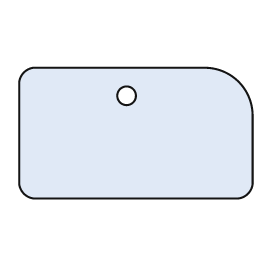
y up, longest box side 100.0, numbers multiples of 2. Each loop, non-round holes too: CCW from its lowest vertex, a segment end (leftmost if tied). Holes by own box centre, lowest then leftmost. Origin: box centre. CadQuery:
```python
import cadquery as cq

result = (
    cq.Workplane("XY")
    .moveTo(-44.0, -28.0)
    .lineTo(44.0, -28.0)
    .threePointArc((48.0, -26.0), (50.0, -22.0))
    .lineTo(50.0, 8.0)
    .threePointArc((44.0, 22.0), (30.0, 28.0))
    .lineTo(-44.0, 28.0)
    .threePointArc((-48.0, 26.0), (-50.0, 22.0))
    .lineTo(-50.0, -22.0)
    .threePointArc((-48.0, -26.0), (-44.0, -28.0))
    .close()
    .moveTo(-4.0, 16.0)
    .circle(4.0)
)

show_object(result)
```